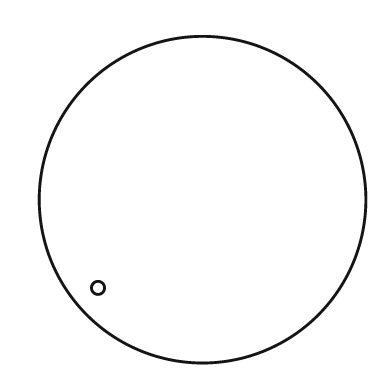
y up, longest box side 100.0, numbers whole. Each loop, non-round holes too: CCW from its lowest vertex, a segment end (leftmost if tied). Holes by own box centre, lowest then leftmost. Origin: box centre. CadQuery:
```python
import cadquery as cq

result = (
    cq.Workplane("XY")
    .moveTo(0.0, 0.0)
    .circle(50.0)
    .moveTo(-32.0, -27.0)
    .circle(2.0)
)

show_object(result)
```